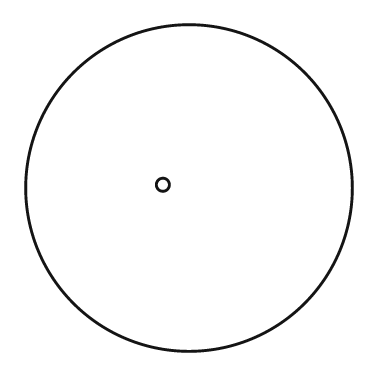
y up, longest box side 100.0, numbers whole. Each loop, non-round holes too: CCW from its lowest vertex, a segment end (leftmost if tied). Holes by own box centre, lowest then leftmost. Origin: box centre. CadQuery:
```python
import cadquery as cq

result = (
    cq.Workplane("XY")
    .moveTo(0.0, 0.0)
    .circle(50.0)
    .moveTo(-8.0, 1.0)
    .circle(2.0)
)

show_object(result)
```